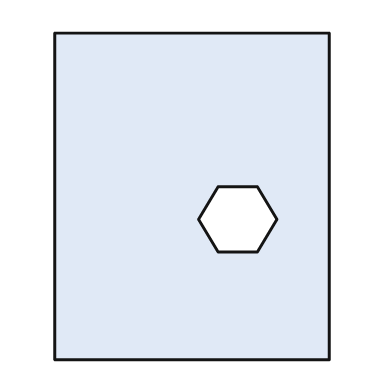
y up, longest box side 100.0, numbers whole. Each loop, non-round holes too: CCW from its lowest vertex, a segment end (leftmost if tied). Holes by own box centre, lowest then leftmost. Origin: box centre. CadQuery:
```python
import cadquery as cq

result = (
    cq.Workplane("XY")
    .moveTo(-42.0, -50.0)
    .lineTo(42.0, -50.0)
    .lineTo(42.0, 50.0)
    .lineTo(-42.0, 50.0)
    .close()
    .moveTo(8.0, -17.0)
    .lineTo(20.0, -17.0)
    .lineTo(26.0, -7.0)
    .lineTo(20.0, 3.0)
    .lineTo(8.0, 3.0)
    .lineTo(2.0, -7.0)
    .close()
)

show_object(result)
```